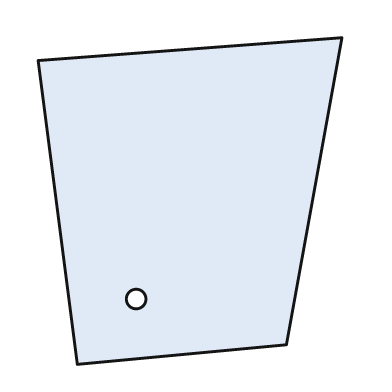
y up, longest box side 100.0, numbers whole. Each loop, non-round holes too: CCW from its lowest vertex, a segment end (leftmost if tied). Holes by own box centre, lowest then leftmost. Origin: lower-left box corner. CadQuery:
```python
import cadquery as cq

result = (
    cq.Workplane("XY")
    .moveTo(12.0, 0.0)
    .lineTo(76.0, 6.0)
    .lineTo(93.0, 100.0)
    .lineTo(0.0, 93.0)
    .close()
    .moveTo(30.0, 20.0)
    .circle(3.0)
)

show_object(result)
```